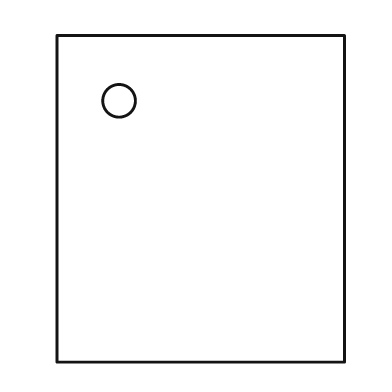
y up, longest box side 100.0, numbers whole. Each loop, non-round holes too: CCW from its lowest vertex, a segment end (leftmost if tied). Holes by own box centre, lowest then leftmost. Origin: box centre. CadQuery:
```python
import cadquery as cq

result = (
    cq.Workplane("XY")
    .moveTo(-44.0, -50.0)
    .lineTo(44.0, -50.0)
    .lineTo(44.0, 50.0)
    .lineTo(-44.0, 50.0)
    .close()
    .moveTo(-25.0, 30.0)
    .circle(5.0)
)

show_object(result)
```